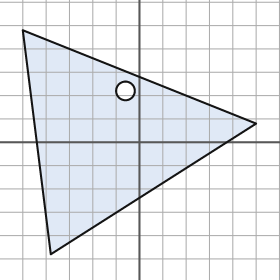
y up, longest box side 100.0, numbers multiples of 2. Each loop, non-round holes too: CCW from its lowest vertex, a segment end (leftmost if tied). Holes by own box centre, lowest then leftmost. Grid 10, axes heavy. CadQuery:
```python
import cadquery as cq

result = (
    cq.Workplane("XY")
    .moveTo(-38.0, -48.0)
    .lineTo(50.0, 8.0)
    .lineTo(-50.0, 48.0)
    .close()
    .moveTo(-6.0, 22.0)
    .circle(4.0)
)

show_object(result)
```